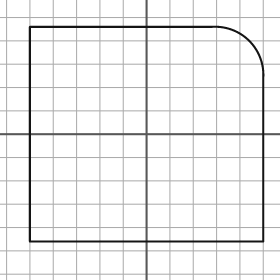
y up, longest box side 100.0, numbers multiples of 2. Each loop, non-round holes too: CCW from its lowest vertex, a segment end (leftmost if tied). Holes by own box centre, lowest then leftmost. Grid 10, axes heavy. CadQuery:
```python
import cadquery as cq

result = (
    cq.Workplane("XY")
    .moveTo(-50.0, -46.0)
    .lineTo(50.0, -46.0)
    .lineTo(50.0, 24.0)
    .threePointArc((44.0, 40.0), (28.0, 46.0))
    .lineTo(-50.0, 46.0)
    .close()
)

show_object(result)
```